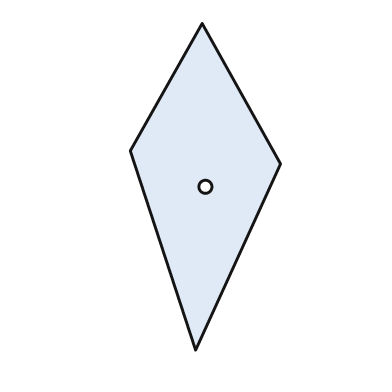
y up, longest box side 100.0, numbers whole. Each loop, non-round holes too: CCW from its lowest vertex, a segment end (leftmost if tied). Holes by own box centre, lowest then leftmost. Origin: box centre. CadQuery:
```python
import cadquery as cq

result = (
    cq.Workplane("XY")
    .moveTo(-3.0, -50.0)
    .lineTo(23.0, 7.0)
    .lineTo(-1.0, 50.0)
    .lineTo(-23.0, 11.0)
    .close()
    .moveTo(0.0, 0.0)
    .circle(2.0)
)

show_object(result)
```